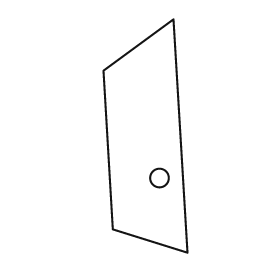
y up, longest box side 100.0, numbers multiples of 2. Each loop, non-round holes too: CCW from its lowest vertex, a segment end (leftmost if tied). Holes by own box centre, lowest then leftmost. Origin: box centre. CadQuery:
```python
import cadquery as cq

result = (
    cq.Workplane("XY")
    .moveTo(18.0, -50.0)
    .lineTo(12.0, 50.0)
    .lineTo(-18.0, 28.0)
    .lineTo(-14.0, -40.0)
    .close()
    .moveTo(6.0, -18.0)
    .circle(4.0)
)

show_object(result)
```